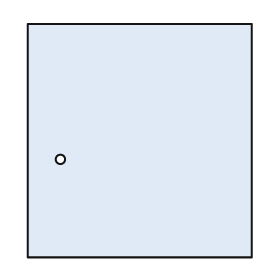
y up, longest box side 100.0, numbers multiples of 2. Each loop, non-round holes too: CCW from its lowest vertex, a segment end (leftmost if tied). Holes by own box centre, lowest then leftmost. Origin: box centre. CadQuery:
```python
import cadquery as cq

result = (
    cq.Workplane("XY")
    .moveTo(-48.0, -50.0)
    .lineTo(48.0, -50.0)
    .lineTo(48.0, 50.0)
    .lineTo(-48.0, 50.0)
    .close()
    .moveTo(-34.0, -8.0)
    .circle(2.0)
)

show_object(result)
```